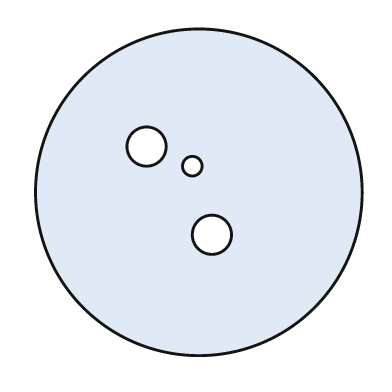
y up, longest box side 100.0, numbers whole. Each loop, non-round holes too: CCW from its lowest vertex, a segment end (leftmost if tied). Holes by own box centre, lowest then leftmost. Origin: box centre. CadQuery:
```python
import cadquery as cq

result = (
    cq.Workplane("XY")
    .moveTo(0.0, 0.0)
    .circle(50.0)
    .moveTo(4.0, -13.0)
    .circle(6.0)
    .moveTo(-2.0, 8.0)
    .circle(3.0)
    .moveTo(-16.0, 14.0)
    .circle(6.0)
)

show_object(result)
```